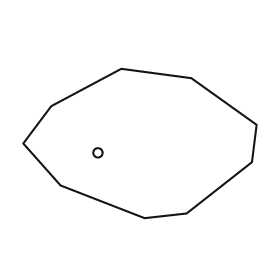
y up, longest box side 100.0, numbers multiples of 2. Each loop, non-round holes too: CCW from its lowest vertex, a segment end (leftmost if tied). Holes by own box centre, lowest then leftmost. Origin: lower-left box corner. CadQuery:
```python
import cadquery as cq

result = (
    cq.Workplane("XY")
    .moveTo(52.0, 0.0)
    .lineTo(70.0, 2.0)
    .lineTo(98.0, 24.0)
    .lineTo(100.0, 40.0)
    .lineTo(72.0, 60.0)
    .lineTo(42.0, 64.0)
    .lineTo(12.0, 48.0)
    .lineTo(0.0, 32.0)
    .lineTo(16.0, 14.0)
    .close()
    .moveTo(32.0, 28.0)
    .circle(2.0)
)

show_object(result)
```